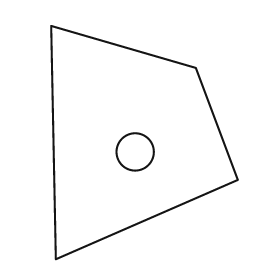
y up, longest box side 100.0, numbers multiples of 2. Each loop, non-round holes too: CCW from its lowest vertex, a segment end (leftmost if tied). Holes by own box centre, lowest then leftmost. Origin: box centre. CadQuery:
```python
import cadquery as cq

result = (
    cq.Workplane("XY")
    .moveTo(-38.0, -50.0)
    .lineTo(40.0, -16.0)
    .lineTo(22.0, 32.0)
    .lineTo(-40.0, 50.0)
    .close()
    .moveTo(-4.0, -4.0)
    .circle(8.0)
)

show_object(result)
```